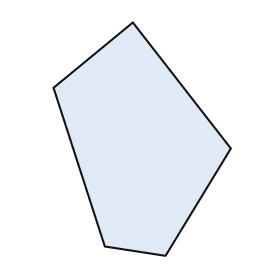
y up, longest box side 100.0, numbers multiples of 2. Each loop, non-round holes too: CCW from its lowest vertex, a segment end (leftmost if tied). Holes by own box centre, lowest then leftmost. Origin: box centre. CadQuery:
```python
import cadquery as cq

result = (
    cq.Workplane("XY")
    .moveTo(10.0, -50.0)
    .lineTo(38.0, -4.0)
    .lineTo(-4.0, 50.0)
    .lineTo(-38.0, 22.0)
    .lineTo(-16.0, -46.0)
    .close()
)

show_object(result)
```